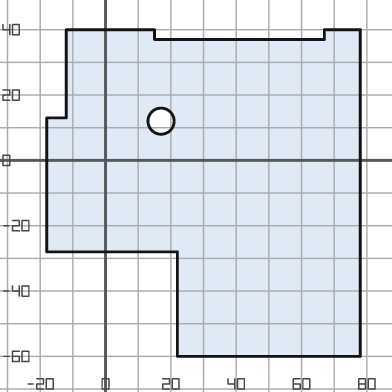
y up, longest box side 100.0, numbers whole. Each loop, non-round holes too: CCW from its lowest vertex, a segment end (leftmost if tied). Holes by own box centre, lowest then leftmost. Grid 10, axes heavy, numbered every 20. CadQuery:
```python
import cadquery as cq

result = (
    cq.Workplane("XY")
    .moveTo(22.0, -60.0)
    .lineTo(78.0, -60.0)
    .lineTo(78.0, 40.0)
    .lineTo(67.0, 40.0)
    .lineTo(67.0, 37.0)
    .lineTo(15.0, 37.0)
    .lineTo(15.0, 40.0)
    .lineTo(-12.0, 40.0)
    .lineTo(-12.0, 13.0)
    .lineTo(-18.0, 13.0)
    .lineTo(-18.0, -28.0)
    .lineTo(22.0, -28.0)
    .close()
    .moveTo(17.0, 12.0)
    .circle(4.0)
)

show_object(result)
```